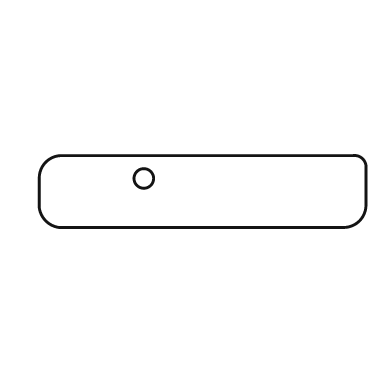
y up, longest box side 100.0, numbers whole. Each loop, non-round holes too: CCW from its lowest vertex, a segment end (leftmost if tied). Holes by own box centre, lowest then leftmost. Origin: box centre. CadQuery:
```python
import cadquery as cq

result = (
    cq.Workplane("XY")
    .moveTo(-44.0, -11.0)
    .lineTo(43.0, -11.0)
    .threePointArc((48.0, -9.0), (50.0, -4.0))
    .lineTo(50.0, 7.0)
    .threePointArc((49.0, 10.0), (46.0, 11.0))
    .lineTo(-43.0, 11.0)
    .threePointArc((-48.0, 9.0), (-50.0, 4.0))
    .lineTo(-50.0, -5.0)
    .threePointArc((-48.0, -9.0), (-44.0, -11.0))
    .close()
    .moveTo(-18.0, 4.0)
    .circle(3.0)
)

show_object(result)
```